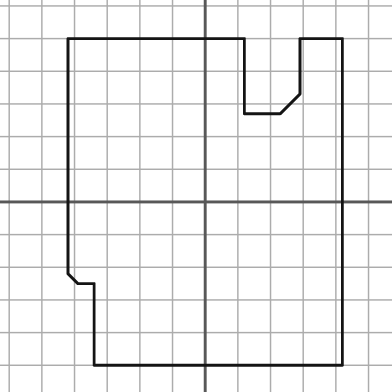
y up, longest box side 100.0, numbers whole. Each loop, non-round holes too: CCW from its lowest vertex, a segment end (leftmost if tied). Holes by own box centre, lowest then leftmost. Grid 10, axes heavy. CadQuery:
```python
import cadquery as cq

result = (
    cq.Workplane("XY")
    .moveTo(-34.0, -50.0)
    .lineTo(42.0, -50.0)
    .lineTo(42.0, 50.0)
    .lineTo(29.0, 50.0)
    .lineTo(29.0, 33.0)
    .lineTo(23.0, 27.0)
    .lineTo(12.0, 27.0)
    .lineTo(12.0, 50.0)
    .lineTo(-42.0, 50.0)
    .lineTo(-42.0, -22.0)
    .lineTo(-39.0, -25.0)
    .lineTo(-34.0, -25.0)
    .close()
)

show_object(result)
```